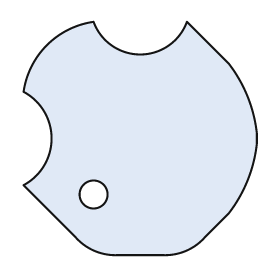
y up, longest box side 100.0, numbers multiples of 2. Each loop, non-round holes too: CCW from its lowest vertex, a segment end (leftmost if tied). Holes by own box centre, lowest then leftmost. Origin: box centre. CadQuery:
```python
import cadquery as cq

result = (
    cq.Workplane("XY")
    .moveTo(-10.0, -50.0)
    .lineTo(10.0, -50.0)
    .threePointArc((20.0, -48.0), (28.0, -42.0))
    .lineTo(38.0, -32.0)
    .threePointArc((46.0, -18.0), (50.0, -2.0))
    .lineTo(50.0, 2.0)
    .threePointArc((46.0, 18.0), (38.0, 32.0))
    .lineTo(20.0, 50.0)
    .threePointArc((0.0, 36.0), (-20.0, 50.0))
    .threePointArc((-40.0, 40.0), (-50.0, 20.0))
    .threePointArc((-38.0, 0.0), (-50.0, -20.0))
    .lineTo(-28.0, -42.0)
    .threePointArc((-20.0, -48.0), (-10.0, -50.0))
    .close()
    .moveTo(-20.0, -24.0)
    .circle(6.0)
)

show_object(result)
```